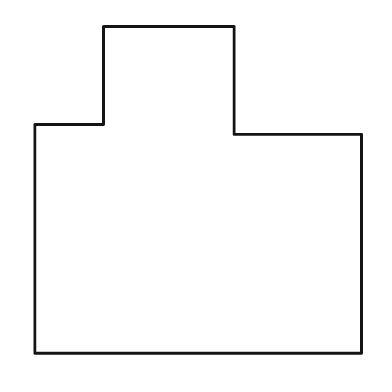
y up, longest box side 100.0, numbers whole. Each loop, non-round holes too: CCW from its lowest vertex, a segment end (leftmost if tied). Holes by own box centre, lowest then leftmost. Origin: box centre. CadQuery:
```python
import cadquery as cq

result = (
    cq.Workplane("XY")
    .moveTo(-50.0, -50.0)
    .lineTo(50.0, -50.0)
    .lineTo(50.0, 17.0)
    .lineTo(11.0, 17.0)
    .lineTo(11.0, 50.0)
    .lineTo(-29.0, 50.0)
    .lineTo(-29.0, 20.0)
    .lineTo(-50.0, 20.0)
    .close()
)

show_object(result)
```